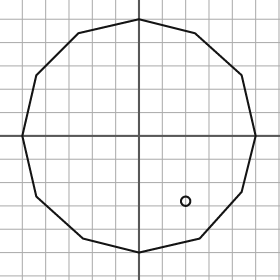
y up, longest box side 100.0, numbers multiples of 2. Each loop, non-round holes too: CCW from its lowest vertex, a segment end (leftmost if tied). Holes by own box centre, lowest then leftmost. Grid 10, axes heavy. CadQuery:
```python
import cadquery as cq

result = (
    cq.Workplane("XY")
    .moveTo(0.0, -50.0)
    .lineTo(26.0, -44.0)
    .lineTo(44.0, -24.0)
    .lineTo(50.0, 0.0)
    .lineTo(44.0, 26.0)
    .lineTo(24.0, 44.0)
    .lineTo(0.0, 50.0)
    .lineTo(-26.0, 44.0)
    .lineTo(-44.0, 26.0)
    .lineTo(-50.0, 0.0)
    .lineTo(-44.0, -26.0)
    .lineTo(-24.0, -44.0)
    .close()
    .moveTo(20.0, -28.0)
    .circle(2.0)
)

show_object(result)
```